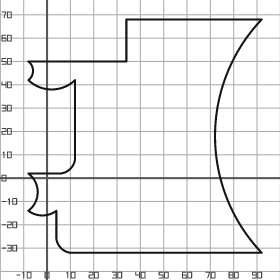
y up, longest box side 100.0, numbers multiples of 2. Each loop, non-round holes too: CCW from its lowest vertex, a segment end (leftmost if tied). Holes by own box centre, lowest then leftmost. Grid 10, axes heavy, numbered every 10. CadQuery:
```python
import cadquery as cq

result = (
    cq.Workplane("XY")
    .moveTo(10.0, -32.0)
    .lineTo(92.0, -32.0)
    .threePointArc((72.0, 18.0), (92.0, 68.0))
    .lineTo(34.0, 68.0)
    .lineTo(34.0, 50.0)
    .lineTo(-8.0, 50.0)
    .threePointArc((-6.0, 46.0), (-8.0, 42.0))
    .threePointArc((2.0, 38.0), (12.0, 42.0))
    .lineTo(12.0, 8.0)
    .threePointArc((10.0, 4.0), (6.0, 2.0))
    .lineTo(-8.0, 2.0)
    .threePointArc((-4.0, -6.0), (-8.0, -14.0))
    .threePointArc((-2.0, -16.0), (4.0, -14.0))
    .lineTo(4.0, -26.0)
    .threePointArc((6.0, -30.0), (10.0, -32.0))
    .close()
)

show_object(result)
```